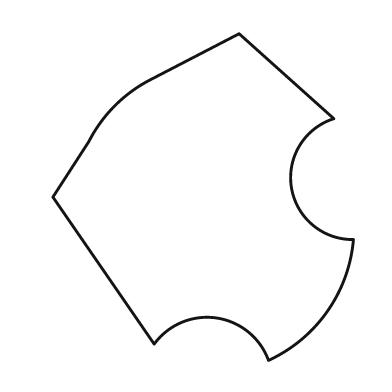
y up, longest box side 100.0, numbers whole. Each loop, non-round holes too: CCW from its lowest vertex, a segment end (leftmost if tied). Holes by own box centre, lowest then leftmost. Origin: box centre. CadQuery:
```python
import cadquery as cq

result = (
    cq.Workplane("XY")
    .moveTo(20.0, -50.0)
    .threePointArc((38.0, -35.0), (46.0, -13.0))
    .threePointArc((27.0, 3.0), (40.0, 24.0))
    .lineTo(11.0, 50.0)
    .lineTo(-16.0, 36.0)
    .threePointArc((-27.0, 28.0), (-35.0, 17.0))
    .lineTo(-46.0, 0.0)
    .lineTo(-15.0, -45.0)
    .threePointArc((4.0, -37.0), (20.0, -50.0))
    .close()
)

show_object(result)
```